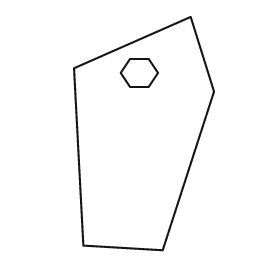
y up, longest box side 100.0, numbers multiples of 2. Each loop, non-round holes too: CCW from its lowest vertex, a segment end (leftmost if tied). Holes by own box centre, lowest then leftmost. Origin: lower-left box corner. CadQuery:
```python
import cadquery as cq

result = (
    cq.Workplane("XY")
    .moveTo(38.0, 0.0)
    .lineTo(60.0, 68.0)
    .lineTo(50.0, 100.0)
    .lineTo(0.0, 78.0)
    .lineTo(4.0, 2.0)
    .close()
    .moveTo(24.0, 70.0)
    .lineTo(32.0, 70.0)
    .lineTo(36.0, 76.0)
    .lineTo(32.0, 82.0)
    .lineTo(24.0, 82.0)
    .lineTo(20.0, 76.0)
    .close()
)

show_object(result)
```